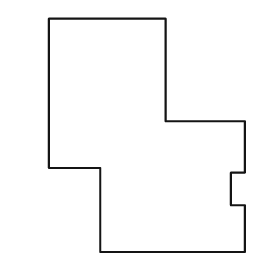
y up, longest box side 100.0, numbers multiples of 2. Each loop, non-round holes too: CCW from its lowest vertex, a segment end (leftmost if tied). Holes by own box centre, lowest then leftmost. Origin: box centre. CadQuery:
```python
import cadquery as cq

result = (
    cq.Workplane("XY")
    .moveTo(-20.0, -50.0)
    .lineTo(42.0, -50.0)
    .lineTo(42.0, -30.0)
    .lineTo(36.0, -30.0)
    .lineTo(36.0, -16.0)
    .lineTo(42.0, -16.0)
    .lineTo(42.0, 6.0)
    .lineTo(8.0, 6.0)
    .lineTo(8.0, 50.0)
    .lineTo(-42.0, 50.0)
    .lineTo(-42.0, -14.0)
    .lineTo(-20.0, -14.0)
    .close()
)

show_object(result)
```